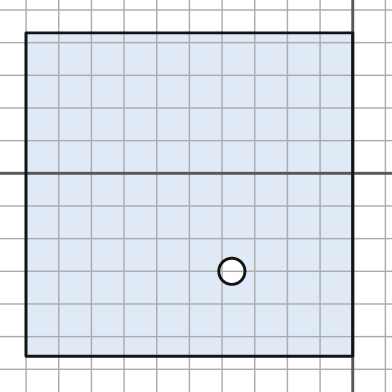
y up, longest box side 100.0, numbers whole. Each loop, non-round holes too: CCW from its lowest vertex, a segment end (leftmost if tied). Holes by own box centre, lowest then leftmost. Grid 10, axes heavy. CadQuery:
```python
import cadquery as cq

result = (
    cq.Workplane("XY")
    .moveTo(-100.0, -56.0)
    .lineTo(0.0, -56.0)
    .lineTo(0.0, 43.0)
    .lineTo(-100.0, 43.0)
    .close()
    .moveTo(-37.0, -30.0)
    .circle(4.0)
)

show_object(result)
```